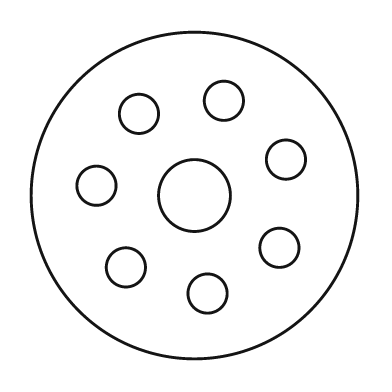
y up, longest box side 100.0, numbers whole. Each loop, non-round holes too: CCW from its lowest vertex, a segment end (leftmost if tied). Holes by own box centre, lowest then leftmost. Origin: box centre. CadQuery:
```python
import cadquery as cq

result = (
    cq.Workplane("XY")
    .moveTo(0.0, 0.0)
    .circle(50.0)
    .moveTo(4.0, -30.0)
    .circle(6.0)
    .moveTo(-21.0, -22.0)
    .circle(6.0)
    .moveTo(26.0, -16.0)
    .circle(6.0)
    .moveTo(0.0, 0.0)
    .circle(11.0)
    .moveTo(-30.0, 3.0)
    .circle(6.0)
    .moveTo(28.0, 11.0)
    .circle(6.0)
    .moveTo(-17.0, 25.0)
    .circle(6.0)
    .moveTo(9.0, 29.0)
    .circle(6.0)
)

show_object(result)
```